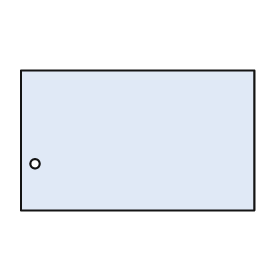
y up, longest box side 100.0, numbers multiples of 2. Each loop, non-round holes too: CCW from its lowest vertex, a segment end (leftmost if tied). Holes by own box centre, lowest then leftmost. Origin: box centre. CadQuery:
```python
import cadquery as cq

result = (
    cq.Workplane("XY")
    .moveTo(-50.0, -30.0)
    .lineTo(50.0, -30.0)
    .lineTo(50.0, 30.0)
    .lineTo(-50.0, 30.0)
    .close()
    .moveTo(-44.0, -10.0)
    .circle(2.0)
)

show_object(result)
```